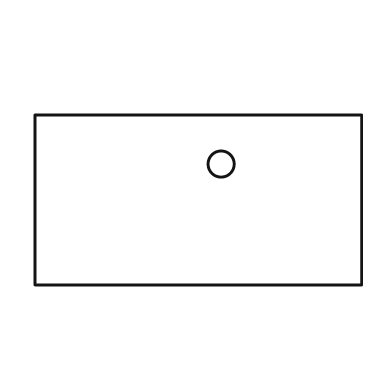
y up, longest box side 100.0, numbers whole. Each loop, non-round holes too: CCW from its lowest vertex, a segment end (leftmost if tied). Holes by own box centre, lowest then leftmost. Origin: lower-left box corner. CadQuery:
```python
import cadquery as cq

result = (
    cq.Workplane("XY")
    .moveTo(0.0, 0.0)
    .lineTo(100.0, 0.0)
    .lineTo(100.0, 52.0)
    .lineTo(0.0, 52.0)
    .close()
    .moveTo(57.0, 37.0)
    .circle(4.0)
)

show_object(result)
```